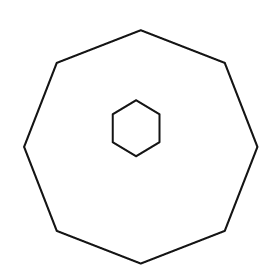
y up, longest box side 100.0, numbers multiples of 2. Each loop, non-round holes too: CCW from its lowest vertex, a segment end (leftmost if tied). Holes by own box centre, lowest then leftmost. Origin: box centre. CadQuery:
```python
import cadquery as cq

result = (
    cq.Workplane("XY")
    .moveTo(0.0, -50.0)
    .lineTo(36.0, -36.0)
    .lineTo(50.0, 0.0)
    .lineTo(36.0, 36.0)
    .lineTo(0.0, 50.0)
    .lineTo(-36.0, 36.0)
    .lineTo(-50.0, 0.0)
    .lineTo(-36.0, -36.0)
    .close()
    .moveTo(-2.0, -4.0)
    .lineTo(8.0, 2.0)
    .lineTo(8.0, 14.0)
    .lineTo(-2.0, 20.0)
    .lineTo(-12.0, 14.0)
    .lineTo(-12.0, 2.0)
    .close()
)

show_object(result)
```